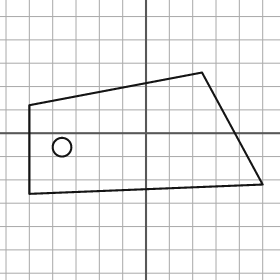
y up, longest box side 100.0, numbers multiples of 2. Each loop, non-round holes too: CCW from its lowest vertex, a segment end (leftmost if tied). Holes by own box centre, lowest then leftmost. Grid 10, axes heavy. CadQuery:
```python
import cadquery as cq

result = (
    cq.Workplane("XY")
    .moveTo(-50.0, -26.0)
    .lineTo(50.0, -22.0)
    .lineTo(24.0, 26.0)
    .lineTo(-50.0, 12.0)
    .close()
    .moveTo(-36.0, -6.0)
    .circle(4.0)
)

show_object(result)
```